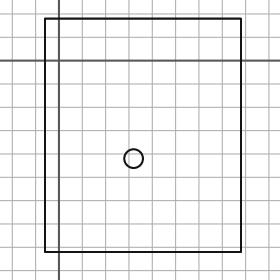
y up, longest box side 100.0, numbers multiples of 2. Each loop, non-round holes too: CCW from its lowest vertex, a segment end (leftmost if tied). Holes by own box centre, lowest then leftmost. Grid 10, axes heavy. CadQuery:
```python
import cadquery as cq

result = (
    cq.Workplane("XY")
    .moveTo(-6.0, -82.0)
    .lineTo(78.0, -82.0)
    .lineTo(78.0, 18.0)
    .lineTo(-6.0, 18.0)
    .close()
    .moveTo(32.0, -42.0)
    .circle(4.0)
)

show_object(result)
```